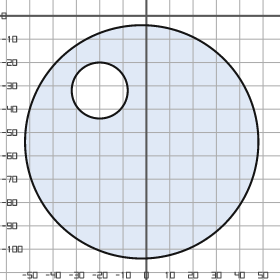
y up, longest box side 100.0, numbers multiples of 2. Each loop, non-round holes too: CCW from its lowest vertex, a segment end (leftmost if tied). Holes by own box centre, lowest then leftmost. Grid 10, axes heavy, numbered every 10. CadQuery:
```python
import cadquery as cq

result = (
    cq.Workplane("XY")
    .moveTo(-2.0, -54.0)
    .circle(50.0)
    .moveTo(-20.0, -32.0)
    .circle(12.0)
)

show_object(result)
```